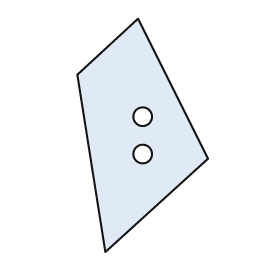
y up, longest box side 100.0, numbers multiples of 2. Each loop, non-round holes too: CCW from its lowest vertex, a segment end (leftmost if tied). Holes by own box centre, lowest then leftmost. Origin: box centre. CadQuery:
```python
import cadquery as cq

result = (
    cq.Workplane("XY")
    .moveTo(-16.0, -50.0)
    .lineTo(28.0, -10.0)
    .lineTo(-2.0, 50.0)
    .lineTo(-28.0, 26.0)
    .close()
    .moveTo(0.0, -8.0)
    .circle(4.0)
    .moveTo(0.0, 8.0)
    .circle(4.0)
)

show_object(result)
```